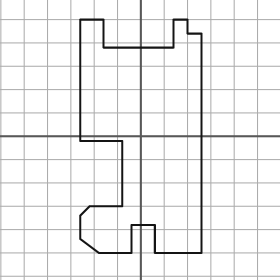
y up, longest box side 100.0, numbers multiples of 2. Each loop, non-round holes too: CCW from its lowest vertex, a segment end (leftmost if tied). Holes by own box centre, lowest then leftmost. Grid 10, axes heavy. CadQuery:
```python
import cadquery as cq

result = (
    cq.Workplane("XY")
    .moveTo(-18.0, -50.0)
    .lineTo(-4.0, -50.0)
    .lineTo(-4.0, -38.0)
    .lineTo(6.0, -38.0)
    .lineTo(6.0, -50.0)
    .lineTo(26.0, -50.0)
    .lineTo(26.0, 44.0)
    .lineTo(20.0, 44.0)
    .lineTo(20.0, 50.0)
    .lineTo(14.0, 50.0)
    .lineTo(14.0, 38.0)
    .lineTo(-16.0, 38.0)
    .lineTo(-16.0, 50.0)
    .lineTo(-26.0, 50.0)
    .lineTo(-26.0, -2.0)
    .lineTo(-8.0, -2.0)
    .lineTo(-8.0, -30.0)
    .lineTo(-22.0, -30.0)
    .lineTo(-26.0, -34.0)
    .lineTo(-26.0, -44.0)
    .close()
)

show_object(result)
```